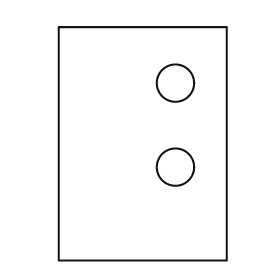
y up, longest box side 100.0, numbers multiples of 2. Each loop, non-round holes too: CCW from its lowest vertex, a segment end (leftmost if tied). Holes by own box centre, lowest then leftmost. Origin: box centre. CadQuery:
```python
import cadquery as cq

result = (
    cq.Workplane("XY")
    .moveTo(-36.0, -50.0)
    .lineTo(36.0, -50.0)
    .lineTo(36.0, 50.0)
    .lineTo(-36.0, 50.0)
    .close()
    .moveTo(14.0, -10.0)
    .circle(8.0)
    .moveTo(14.0, 26.0)
    .circle(8.0)
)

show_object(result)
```